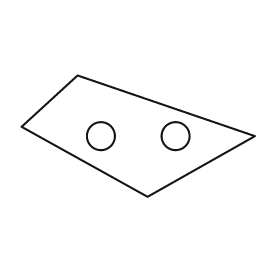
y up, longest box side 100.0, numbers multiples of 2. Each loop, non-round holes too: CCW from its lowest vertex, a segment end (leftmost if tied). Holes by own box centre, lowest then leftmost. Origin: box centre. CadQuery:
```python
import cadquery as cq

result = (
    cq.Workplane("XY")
    .moveTo(4.0, -26.0)
    .lineTo(50.0, 0.0)
    .lineTo(-26.0, 26.0)
    .lineTo(-50.0, 4.0)
    .close()
    .moveTo(-16.0, 0.0)
    .circle(6.0)
    .moveTo(16.0, 0.0)
    .circle(6.0)
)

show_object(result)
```